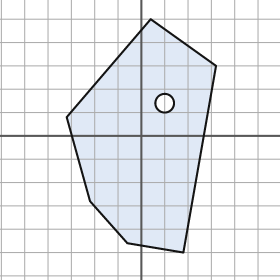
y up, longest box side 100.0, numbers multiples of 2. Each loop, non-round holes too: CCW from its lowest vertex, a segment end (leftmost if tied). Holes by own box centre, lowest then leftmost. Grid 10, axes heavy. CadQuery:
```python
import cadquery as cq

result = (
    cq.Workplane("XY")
    .moveTo(18.0, -50.0)
    .lineTo(32.0, 30.0)
    .lineTo(4.0, 50.0)
    .lineTo(-32.0, 8.0)
    .lineTo(-22.0, -28.0)
    .lineTo(-6.0, -46.0)
    .close()
    .moveTo(10.0, 14.0)
    .circle(4.0)
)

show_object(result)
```